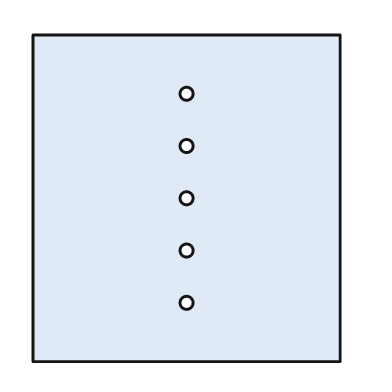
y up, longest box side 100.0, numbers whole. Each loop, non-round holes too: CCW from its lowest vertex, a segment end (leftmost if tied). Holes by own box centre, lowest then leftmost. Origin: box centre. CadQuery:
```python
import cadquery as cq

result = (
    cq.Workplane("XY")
    .moveTo(-47.0, -50.0)
    .lineTo(47.0, -50.0)
    .lineTo(47.0, 50.0)
    .lineTo(-47.0, 50.0)
    .close()
    .moveTo(0.0, -32.0)
    .circle(2.0)
    .moveTo(0.0, -16.0)
    .circle(2.0)
    .moveTo(0.0, 0.0)
    .circle(2.0)
    .moveTo(0.0, 16.0)
    .circle(2.0)
    .moveTo(0.0, 32.0)
    .circle(2.0)
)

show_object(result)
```